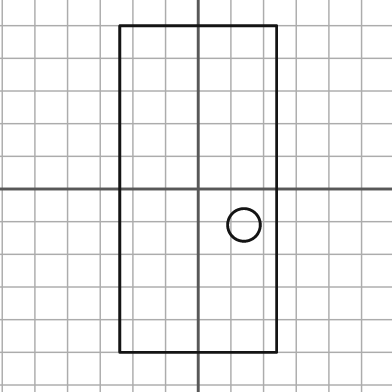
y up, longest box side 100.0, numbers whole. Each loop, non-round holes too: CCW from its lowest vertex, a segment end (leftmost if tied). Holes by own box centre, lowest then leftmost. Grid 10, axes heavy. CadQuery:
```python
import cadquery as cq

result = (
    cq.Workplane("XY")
    .moveTo(-24.0, -50.0)
    .lineTo(24.0, -50.0)
    .lineTo(24.0, 50.0)
    .lineTo(-24.0, 50.0)
    .close()
    .moveTo(14.0, -11.0)
    .circle(5.0)
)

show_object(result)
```